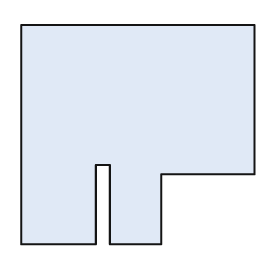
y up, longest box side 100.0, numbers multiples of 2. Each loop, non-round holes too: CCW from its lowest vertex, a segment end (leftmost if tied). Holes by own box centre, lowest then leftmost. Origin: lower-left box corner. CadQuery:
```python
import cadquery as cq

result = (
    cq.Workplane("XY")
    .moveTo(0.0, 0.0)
    .lineTo(32.0, 0.0)
    .lineTo(32.0, 34.0)
    .lineTo(38.0, 34.0)
    .lineTo(38.0, 0.0)
    .lineTo(60.0, 0.0)
    .lineTo(60.0, 30.0)
    .lineTo(100.0, 30.0)
    .lineTo(100.0, 94.0)
    .lineTo(0.0, 94.0)
    .close()
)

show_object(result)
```